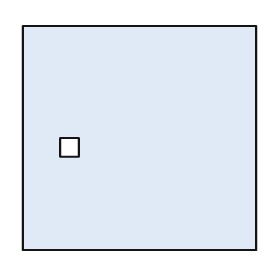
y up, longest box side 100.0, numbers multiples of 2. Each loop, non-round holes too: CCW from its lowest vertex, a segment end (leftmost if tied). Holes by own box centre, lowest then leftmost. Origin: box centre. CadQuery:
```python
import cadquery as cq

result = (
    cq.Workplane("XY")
    .moveTo(-50.0, -48.0)
    .lineTo(50.0, -48.0)
    .lineTo(50.0, 48.0)
    .lineTo(-50.0, 48.0)
    .close()
    .moveTo(-34.0, -8.0)
    .lineTo(-26.0, -8.0)
    .lineTo(-26.0, 0.0)
    .lineTo(-34.0, 0.0)
    .close()
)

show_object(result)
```